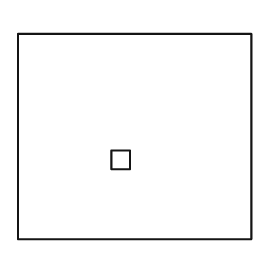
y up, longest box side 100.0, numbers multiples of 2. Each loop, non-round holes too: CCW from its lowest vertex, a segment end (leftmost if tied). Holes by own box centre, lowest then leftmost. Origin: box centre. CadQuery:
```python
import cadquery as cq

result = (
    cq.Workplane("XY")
    .moveTo(-50.0, -44.0)
    .lineTo(50.0, -44.0)
    .lineTo(50.0, 44.0)
    .lineTo(-50.0, 44.0)
    .close()
    .moveTo(-10.0, -14.0)
    .lineTo(-2.0, -14.0)
    .lineTo(-2.0, -6.0)
    .lineTo(-10.0, -6.0)
    .close()
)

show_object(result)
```